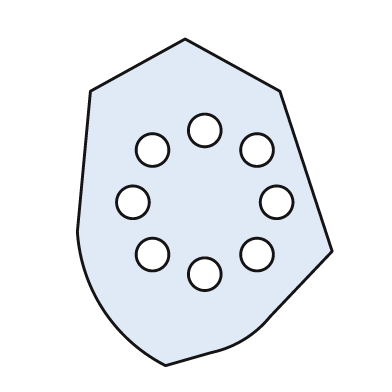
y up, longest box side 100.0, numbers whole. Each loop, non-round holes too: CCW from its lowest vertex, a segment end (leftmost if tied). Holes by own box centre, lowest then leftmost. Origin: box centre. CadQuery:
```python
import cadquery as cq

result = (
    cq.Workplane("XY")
    .moveTo(-12.0, -50.0)
    .lineTo(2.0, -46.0)
    .threePointArc((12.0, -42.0), (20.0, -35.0))
    .lineTo(39.0, -15.0)
    .lineTo(23.0, 34.0)
    .lineTo(-6.0, 50.0)
    .lineTo(-35.0, 34.0)
    .lineTo(-39.0, -9.0)
    .threePointArc((-31.0, -33.0), (-12.0, -50.0))
    .close()
    .moveTo(0.0, -22.0)
    .circle(5.0)
    .moveTo(-16.0, -16.0)
    .circle(5.0)
    .moveTo(16.0, -16.0)
    .circle(5.0)
    .moveTo(-22.0, 0.0)
    .circle(5.0)
    .moveTo(22.0, 0.0)
    .circle(5.0)
    .moveTo(-16.0, 16.0)
    .circle(5.0)
    .moveTo(16.0, 16.0)
    .circle(5.0)
    .moveTo(0.0, 22.0)
    .circle(5.0)
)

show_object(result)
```